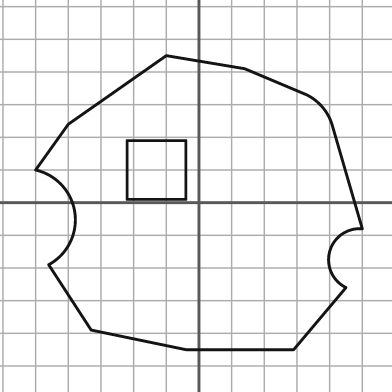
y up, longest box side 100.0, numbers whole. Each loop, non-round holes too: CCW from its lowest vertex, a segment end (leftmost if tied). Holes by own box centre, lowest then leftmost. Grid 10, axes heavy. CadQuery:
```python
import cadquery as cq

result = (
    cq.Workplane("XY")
    .moveTo(-4.0, -45.0)
    .lineTo(29.0, -45.0)
    .lineTo(45.0, -26.0)
    .threePointArc((40.0, -15.0), (50.0, -8.0))
    .lineTo(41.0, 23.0)
    .threePointArc((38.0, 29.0), (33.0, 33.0))
    .lineTo(14.0, 41.0)
    .lineTo(-10.0, 45.0)
    .lineTo(-40.0, 24.0)
    .lineTo(-50.0, 10.0)
    .threePointArc((-38.0, -3.0), (-46.0, -19.0))
    .lineTo(-33.0, -39.0)
    .close()
    .moveTo(-22.0, 1.0)
    .lineTo(-4.0, 1.0)
    .lineTo(-4.0, 19.0)
    .lineTo(-22.0, 19.0)
    .close()
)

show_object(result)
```